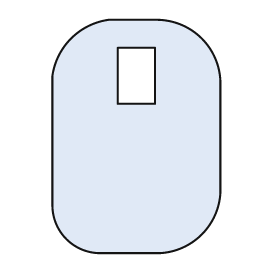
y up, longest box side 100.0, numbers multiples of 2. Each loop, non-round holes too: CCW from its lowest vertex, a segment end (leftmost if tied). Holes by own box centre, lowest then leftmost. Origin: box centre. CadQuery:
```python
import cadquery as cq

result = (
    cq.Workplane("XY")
    .moveTo(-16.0, -50.0)
    .lineTo(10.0, -50.0)
    .threePointArc((28.0, -42.0), (36.0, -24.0))
    .lineTo(36.0, 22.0)
    .threePointArc((28.0, 42.0), (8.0, 50.0))
    .lineTo(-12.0, 50.0)
    .threePointArc((-28.0, 42.0), (-36.0, 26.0))
    .lineTo(-36.0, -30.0)
    .threePointArc((-30.0, -44.0), (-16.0, -50.0))
    .close()
    .moveTo(-8.0, 14.0)
    .lineTo(8.0, 14.0)
    .lineTo(8.0, 38.0)
    .lineTo(-8.0, 38.0)
    .close()
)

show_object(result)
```